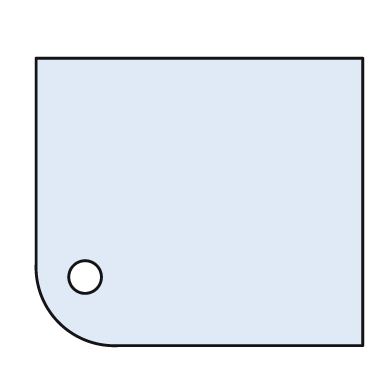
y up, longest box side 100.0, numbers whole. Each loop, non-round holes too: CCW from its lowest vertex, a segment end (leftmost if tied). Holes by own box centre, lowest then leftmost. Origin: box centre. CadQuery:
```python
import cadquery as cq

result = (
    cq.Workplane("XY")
    .moveTo(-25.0, -44.0)
    .lineTo(50.0, -44.0)
    .lineTo(50.0, 44.0)
    .lineTo(-50.0, 44.0)
    .lineTo(-50.0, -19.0)
    .threePointArc((-43.0, -37.0), (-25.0, -44.0))
    .close()
    .moveTo(-35.0, -23.0)
    .circle(5.0)
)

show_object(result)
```